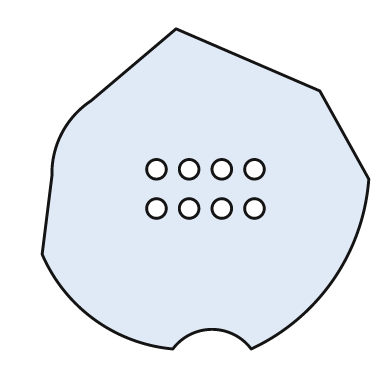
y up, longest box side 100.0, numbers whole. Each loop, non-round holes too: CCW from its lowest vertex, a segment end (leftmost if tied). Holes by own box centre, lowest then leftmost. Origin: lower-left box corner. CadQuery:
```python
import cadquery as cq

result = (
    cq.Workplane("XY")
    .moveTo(40.0, 0.0)
    .threePointArc((52.0, 6.0), (64.0, 0.0))
    .threePointArc((89.0, 21.0), (100.0, 52.0))
    .lineTo(85.0, 79.0)
    .lineTo(41.0, 98.0)
    .lineTo(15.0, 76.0)
    .threePointArc((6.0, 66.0), (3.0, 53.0))
    .lineTo(0.0, 29.0)
    .threePointArc((16.0, 9.0), (40.0, 0.0))
    .close()
    .moveTo(35.0, 43.0)
    .circle(3.0)
    .moveTo(45.0, 43.0)
    .circle(3.0)
    .moveTo(55.0, 43.0)
    .circle(3.0)
    .moveTo(65.0, 43.0)
    .circle(3.0)
    .moveTo(35.0, 55.0)
    .circle(3.0)
    .moveTo(45.0, 55.0)
    .circle(3.0)
    .moveTo(55.0, 55.0)
    .circle(3.0)
    .moveTo(65.0, 55.0)
    .circle(3.0)
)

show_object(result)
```